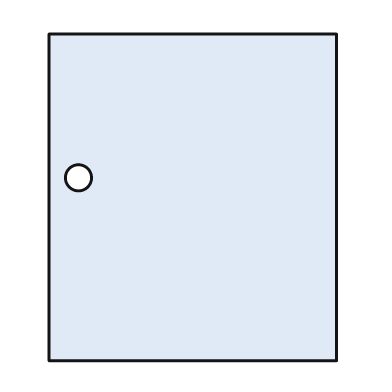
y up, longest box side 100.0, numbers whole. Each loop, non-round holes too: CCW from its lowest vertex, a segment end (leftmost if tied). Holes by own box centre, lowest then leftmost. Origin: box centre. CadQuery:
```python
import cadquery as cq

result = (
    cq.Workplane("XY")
    .moveTo(-44.0, -50.0)
    .lineTo(44.0, -50.0)
    .lineTo(44.0, 50.0)
    .lineTo(-44.0, 50.0)
    .close()
    .moveTo(-35.0, 6.0)
    .circle(4.0)
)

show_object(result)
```